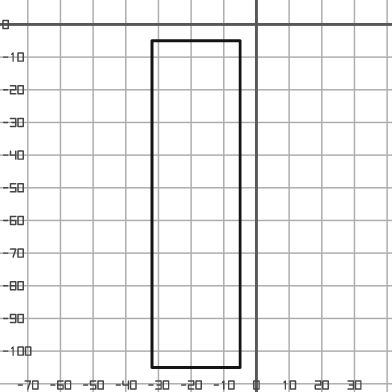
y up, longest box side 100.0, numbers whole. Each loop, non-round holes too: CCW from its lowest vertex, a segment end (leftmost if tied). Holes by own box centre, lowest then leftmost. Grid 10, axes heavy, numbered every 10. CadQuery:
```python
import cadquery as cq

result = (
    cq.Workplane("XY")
    .moveTo(-32.0, -105.0)
    .lineTo(-5.0, -105.0)
    .lineTo(-5.0, -5.0)
    .lineTo(-32.0, -5.0)
    .close()
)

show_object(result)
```